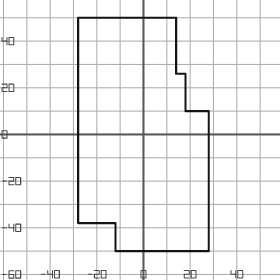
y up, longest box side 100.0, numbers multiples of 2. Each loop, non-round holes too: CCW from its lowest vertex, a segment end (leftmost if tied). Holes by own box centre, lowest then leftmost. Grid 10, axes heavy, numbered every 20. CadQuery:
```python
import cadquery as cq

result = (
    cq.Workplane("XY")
    .moveTo(-12.0, -50.0)
    .lineTo(28.0, -50.0)
    .lineTo(28.0, 10.0)
    .lineTo(18.0, 10.0)
    .lineTo(18.0, 26.0)
    .lineTo(14.0, 26.0)
    .lineTo(14.0, 50.0)
    .lineTo(-28.0, 50.0)
    .lineTo(-28.0, -38.0)
    .lineTo(-12.0, -38.0)
    .close()
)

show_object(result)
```